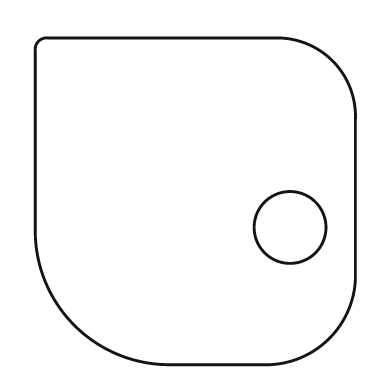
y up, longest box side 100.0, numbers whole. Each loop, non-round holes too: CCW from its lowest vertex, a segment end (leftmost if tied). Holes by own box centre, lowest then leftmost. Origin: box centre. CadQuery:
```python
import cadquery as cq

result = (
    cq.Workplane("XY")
    .moveTo(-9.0, -50.0)
    .lineTo(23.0, -50.0)
    .threePointArc((41.0, -42.0), (49.0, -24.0))
    .lineTo(49.0, 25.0)
    .threePointArc((42.0, 43.0), (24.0, 50.0))
    .lineTo(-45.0, 50.0)
    .threePointArc((-48.0, 49.0), (-49.0, 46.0))
    .lineTo(-49.0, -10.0)
    .threePointArc((-37.0, -38.0), (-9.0, -50.0))
    .close()
    .moveTo(29.0, -8.0)
    .circle(11.0)
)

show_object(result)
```